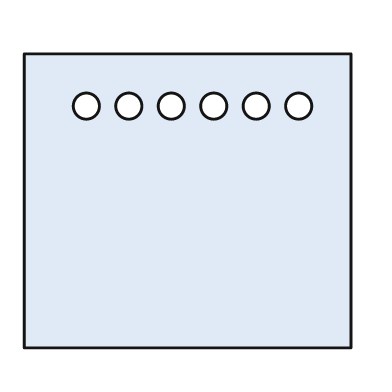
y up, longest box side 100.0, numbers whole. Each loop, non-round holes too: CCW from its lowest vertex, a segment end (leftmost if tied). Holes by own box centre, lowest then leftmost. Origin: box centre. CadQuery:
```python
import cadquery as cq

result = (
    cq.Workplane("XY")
    .moveTo(-50.0, -45.0)
    .lineTo(50.0, -45.0)
    .lineTo(50.0, 45.0)
    .lineTo(-50.0, 45.0)
    .close()
    .moveTo(-31.0, 29.0)
    .circle(4.0)
    .moveTo(-18.0, 29.0)
    .circle(4.0)
    .moveTo(-5.0, 29.0)
    .circle(4.0)
    .moveTo(8.0, 29.0)
    .circle(4.0)
    .moveTo(21.0, 29.0)
    .circle(4.0)
    .moveTo(34.0, 29.0)
    .circle(4.0)
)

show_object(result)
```